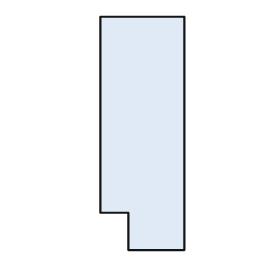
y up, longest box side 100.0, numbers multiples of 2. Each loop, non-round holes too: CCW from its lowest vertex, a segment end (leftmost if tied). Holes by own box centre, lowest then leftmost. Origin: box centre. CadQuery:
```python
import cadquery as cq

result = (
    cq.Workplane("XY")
    .moveTo(-6.0, -50.0)
    .lineTo(18.0, -50.0)
    .lineTo(18.0, 50.0)
    .lineTo(-18.0, 50.0)
    .lineTo(-18.0, -34.0)
    .lineTo(-6.0, -34.0)
    .close()
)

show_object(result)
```